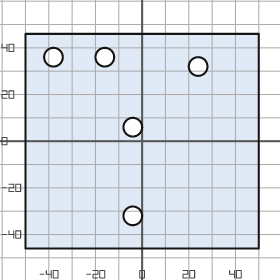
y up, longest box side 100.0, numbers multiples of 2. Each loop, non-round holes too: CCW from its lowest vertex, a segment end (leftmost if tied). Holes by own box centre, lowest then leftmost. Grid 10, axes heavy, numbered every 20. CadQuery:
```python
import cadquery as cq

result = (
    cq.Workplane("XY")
    .moveTo(-50.0, -46.0)
    .lineTo(50.0, -46.0)
    .lineTo(50.0, 46.0)
    .lineTo(-50.0, 46.0)
    .close()
    .moveTo(-4.0, -32.0)
    .circle(4.0)
    .moveTo(-4.0, 6.0)
    .circle(4.0)
    .moveTo(24.0, 32.0)
    .circle(4.0)
    .moveTo(-38.0, 36.0)
    .circle(4.0)
    .moveTo(-16.0, 36.0)
    .circle(4.0)
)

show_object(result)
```